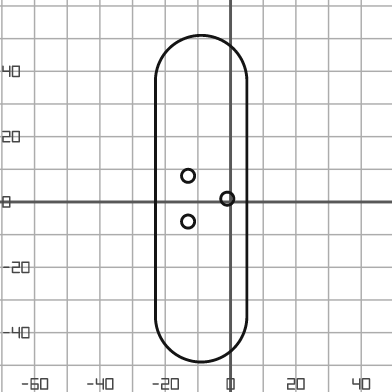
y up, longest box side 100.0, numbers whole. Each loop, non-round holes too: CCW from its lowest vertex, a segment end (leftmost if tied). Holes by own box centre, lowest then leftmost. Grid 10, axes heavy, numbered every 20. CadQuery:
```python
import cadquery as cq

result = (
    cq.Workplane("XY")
    .moveTo(-23.0, -35.0)
    .threePointArc((-9.0, -49.0), (5.0, -35.0))
    .lineTo(5.0, 37.0)
    .threePointArc((-9.0, 51.0), (-23.0, 37.0))
    .close()
    .moveTo(-13.0, -6.0)
    .circle(2.0)
    .moveTo(-1.0, 1.0)
    .circle(2.0)
    .moveTo(-13.0, 8.0)
    .circle(2.0)
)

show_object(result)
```